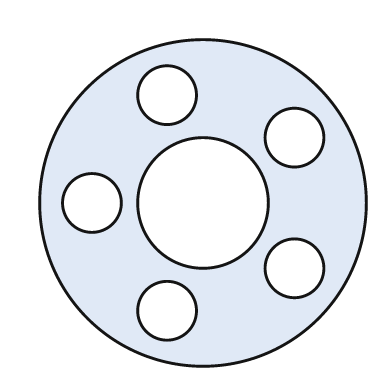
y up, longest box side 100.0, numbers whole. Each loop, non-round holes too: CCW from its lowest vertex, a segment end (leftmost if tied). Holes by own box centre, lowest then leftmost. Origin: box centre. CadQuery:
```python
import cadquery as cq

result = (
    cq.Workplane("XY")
    .moveTo(0.0, 0.0)
    .circle(50.0)
    .moveTo(-11.0, -33.0)
    .circle(9.0)
    .moveTo(28.0, -20.0)
    .circle(9.0)
    .moveTo(-34.0, 0.0)
    .circle(9.0)
    .moveTo(0.0, 0.0)
    .circle(20.0)
    .moveTo(28.0, 20.0)
    .circle(9.0)
    .moveTo(-11.0, 33.0)
    .circle(9.0)
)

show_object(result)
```